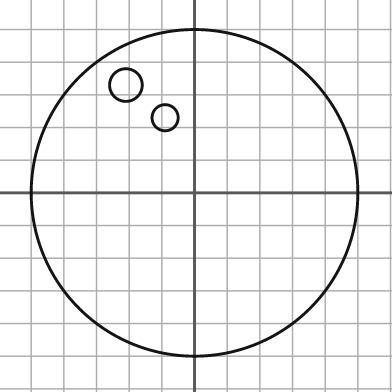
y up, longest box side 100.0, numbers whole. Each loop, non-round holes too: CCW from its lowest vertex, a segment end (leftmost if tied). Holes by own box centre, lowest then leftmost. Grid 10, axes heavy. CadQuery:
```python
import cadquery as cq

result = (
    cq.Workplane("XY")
    .moveTo(0.0, 0.0)
    .circle(50.0)
    .moveTo(-9.0, 23.0)
    .circle(4.0)
    .moveTo(-21.0, 33.0)
    .circle(5.0)
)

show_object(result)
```